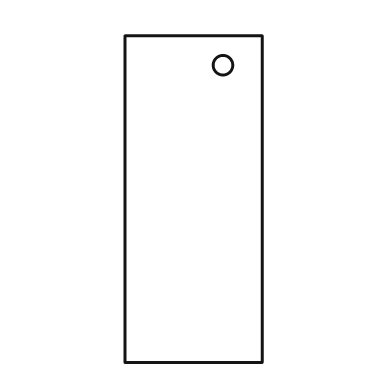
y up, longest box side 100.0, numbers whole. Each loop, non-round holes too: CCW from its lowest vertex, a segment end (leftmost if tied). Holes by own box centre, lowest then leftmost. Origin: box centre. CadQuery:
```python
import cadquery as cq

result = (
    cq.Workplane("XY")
    .moveTo(-21.0, -50.0)
    .lineTo(21.0, -50.0)
    .lineTo(21.0, 50.0)
    .lineTo(-21.0, 50.0)
    .close()
    .moveTo(9.0, 41.0)
    .circle(3.0)
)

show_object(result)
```